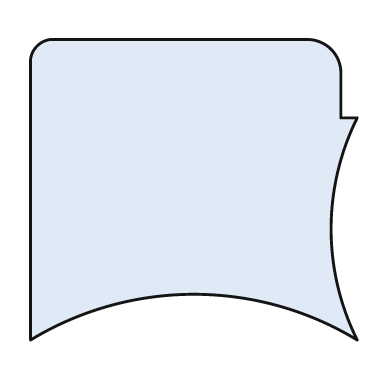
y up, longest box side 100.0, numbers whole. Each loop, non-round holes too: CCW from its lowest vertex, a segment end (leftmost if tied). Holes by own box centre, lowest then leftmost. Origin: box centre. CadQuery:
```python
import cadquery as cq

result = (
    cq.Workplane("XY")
    .moveTo(-50.0, -46.0)
    .threePointArc((0.0, -32.0), (50.0, -46.0))
    .threePointArc((42.0, -12.0), (50.0, 22.0))
    .lineTo(45.0, 22.0)
    .lineTo(45.0, 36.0)
    .threePointArc((42.0, 43.0), (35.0, 46.0))
    .lineTo(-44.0, 46.0)
    .threePointArc((-48.0, 44.0), (-50.0, 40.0))
    .close()
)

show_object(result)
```